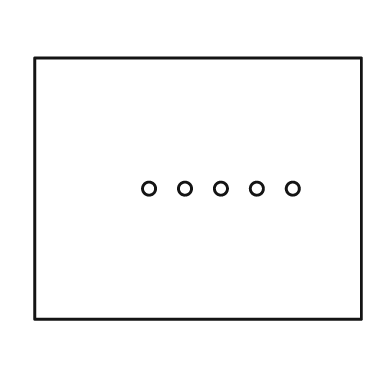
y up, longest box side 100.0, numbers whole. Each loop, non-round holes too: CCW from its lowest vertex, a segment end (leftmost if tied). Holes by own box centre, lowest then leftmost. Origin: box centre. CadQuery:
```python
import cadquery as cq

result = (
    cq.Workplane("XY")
    .moveTo(-50.0, -40.0)
    .lineTo(50.0, -40.0)
    .lineTo(50.0, 40.0)
    .lineTo(-50.0, 40.0)
    .close()
    .moveTo(-15.0, 0.0)
    .circle(2.0)
    .moveTo(-4.0, 0.0)
    .circle(2.0)
    .moveTo(7.0, 0.0)
    .circle(2.0)
    .moveTo(18.0, 0.0)
    .circle(2.0)
    .moveTo(29.0, 0.0)
    .circle(2.0)
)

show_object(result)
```